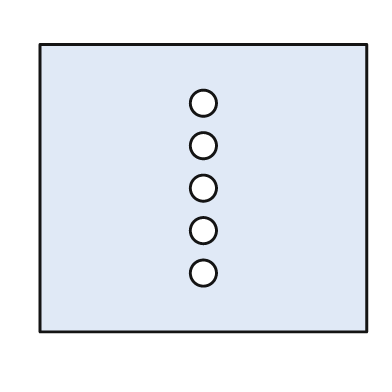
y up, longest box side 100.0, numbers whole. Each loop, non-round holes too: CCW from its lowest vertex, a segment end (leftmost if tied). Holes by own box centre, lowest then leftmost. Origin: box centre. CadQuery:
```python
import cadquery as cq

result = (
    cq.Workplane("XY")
    .moveTo(-50.0, -44.0)
    .lineTo(50.0, -44.0)
    .lineTo(50.0, 44.0)
    .lineTo(-50.0, 44.0)
    .close()
    .moveTo(0.0, -26.0)
    .circle(4.0)
    .moveTo(0.0, -13.0)
    .circle(4.0)
    .moveTo(0.0, 0.0)
    .circle(4.0)
    .moveTo(0.0, 13.0)
    .circle(4.0)
    .moveTo(0.0, 26.0)
    .circle(4.0)
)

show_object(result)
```